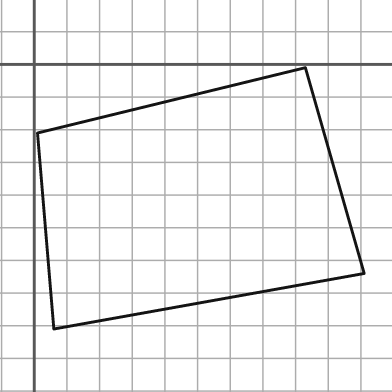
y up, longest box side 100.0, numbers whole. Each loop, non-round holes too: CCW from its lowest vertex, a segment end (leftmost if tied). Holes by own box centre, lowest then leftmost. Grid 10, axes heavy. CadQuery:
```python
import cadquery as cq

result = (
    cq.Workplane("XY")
    .moveTo(6.0, -81.0)
    .lineTo(101.0, -64.0)
    .lineTo(83.0, -1.0)
    .lineTo(1.0, -21.0)
    .close()
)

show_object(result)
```